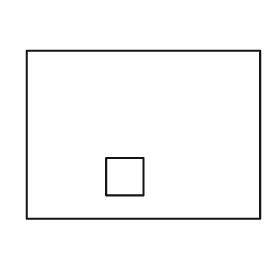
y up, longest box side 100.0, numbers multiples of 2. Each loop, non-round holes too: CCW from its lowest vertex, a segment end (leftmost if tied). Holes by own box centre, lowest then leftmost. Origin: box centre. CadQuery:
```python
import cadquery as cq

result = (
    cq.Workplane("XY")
    .moveTo(-50.0, -36.0)
    .lineTo(50.0, -36.0)
    .lineTo(50.0, 36.0)
    .lineTo(-50.0, 36.0)
    .close()
    .moveTo(-16.0, -26.0)
    .lineTo(0.0, -26.0)
    .lineTo(0.0, -10.0)
    .lineTo(-16.0, -10.0)
    .close()
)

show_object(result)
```